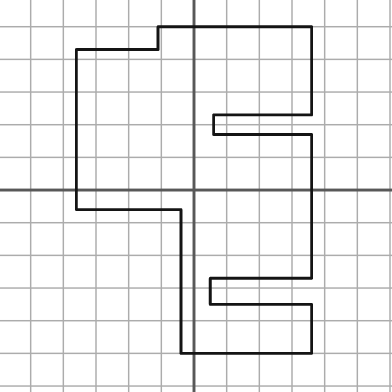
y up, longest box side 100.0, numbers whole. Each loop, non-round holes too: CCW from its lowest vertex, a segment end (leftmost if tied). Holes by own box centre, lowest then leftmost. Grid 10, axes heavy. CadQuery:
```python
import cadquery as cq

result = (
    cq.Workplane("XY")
    .moveTo(-4.0, -50.0)
    .lineTo(36.0, -50.0)
    .lineTo(36.0, -35.0)
    .lineTo(5.0, -35.0)
    .lineTo(5.0, -27.0)
    .lineTo(36.0, -27.0)
    .lineTo(36.0, 17.0)
    .lineTo(6.0, 17.0)
    .lineTo(6.0, 23.0)
    .lineTo(36.0, 23.0)
    .lineTo(36.0, 50.0)
    .lineTo(-11.0, 50.0)
    .lineTo(-11.0, 43.0)
    .lineTo(-36.0, 43.0)
    .lineTo(-36.0, -6.0)
    .lineTo(-4.0, -6.0)
    .close()
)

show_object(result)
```